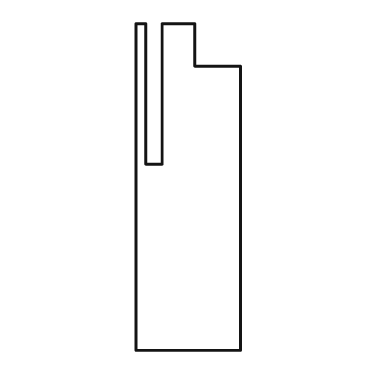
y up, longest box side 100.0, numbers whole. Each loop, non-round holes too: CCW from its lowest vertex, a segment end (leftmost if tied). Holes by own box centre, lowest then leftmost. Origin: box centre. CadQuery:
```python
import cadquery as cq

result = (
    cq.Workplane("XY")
    .moveTo(-16.0, -50.0)
    .lineTo(16.0, -50.0)
    .lineTo(16.0, 37.0)
    .lineTo(2.0, 37.0)
    .lineTo(2.0, 50.0)
    .lineTo(-8.0, 50.0)
    .lineTo(-8.0, 7.0)
    .lineTo(-13.0, 7.0)
    .lineTo(-13.0, 50.0)
    .lineTo(-16.0, 50.0)
    .close()
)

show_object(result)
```